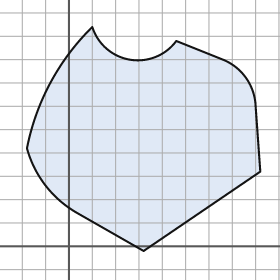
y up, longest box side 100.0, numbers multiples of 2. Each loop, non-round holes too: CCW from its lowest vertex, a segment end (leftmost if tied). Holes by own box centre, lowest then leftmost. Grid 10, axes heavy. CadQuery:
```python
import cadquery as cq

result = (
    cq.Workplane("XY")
    .moveTo(32.0, -2.0)
    .lineTo(82.0, 32.0)
    .lineTo(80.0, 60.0)
    .threePointArc((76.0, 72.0), (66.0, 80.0))
    .lineTo(46.0, 88.0)
    .threePointArc((26.0, 80.0), (10.0, 94.0))
    .threePointArc((-8.0, 70.0), (-18.0, 42.0))
    .threePointArc((-10.0, 26.0), (4.0, 14.0))
    .close()
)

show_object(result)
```